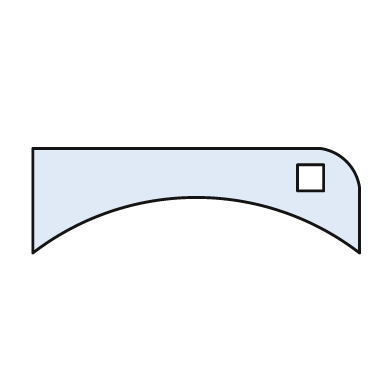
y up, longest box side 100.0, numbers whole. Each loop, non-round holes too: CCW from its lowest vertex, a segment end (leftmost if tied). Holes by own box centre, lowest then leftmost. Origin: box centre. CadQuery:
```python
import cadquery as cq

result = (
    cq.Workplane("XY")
    .moveTo(-50.0, -16.0)
    .threePointArc((0.0, 1.0), (50.0, -16.0))
    .lineTo(50.0, 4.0)
    .threePointArc((46.0, 12.0), (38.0, 16.0))
    .lineTo(-50.0, 16.0)
    .close()
    .moveTo(31.0, 3.0)
    .lineTo(39.0, 3.0)
    .lineTo(39.0, 11.0)
    .lineTo(31.0, 11.0)
    .close()
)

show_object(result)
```